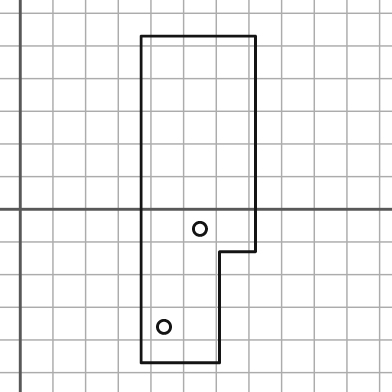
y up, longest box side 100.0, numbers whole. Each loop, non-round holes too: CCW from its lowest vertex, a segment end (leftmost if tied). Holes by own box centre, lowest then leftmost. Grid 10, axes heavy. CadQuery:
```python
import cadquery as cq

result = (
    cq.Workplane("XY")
    .moveTo(37.0, -47.0)
    .lineTo(61.0, -47.0)
    .lineTo(61.0, -13.0)
    .lineTo(72.0, -13.0)
    .lineTo(72.0, 53.0)
    .lineTo(37.0, 53.0)
    .close()
    .moveTo(44.0, -36.0)
    .circle(2.0)
    .moveTo(55.0, -6.0)
    .circle(2.0)
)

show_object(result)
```